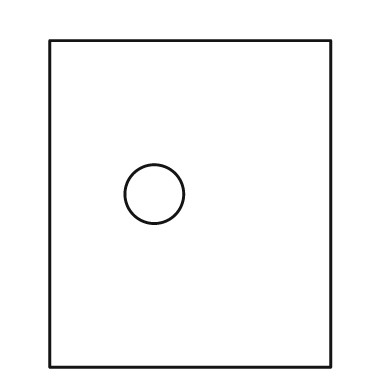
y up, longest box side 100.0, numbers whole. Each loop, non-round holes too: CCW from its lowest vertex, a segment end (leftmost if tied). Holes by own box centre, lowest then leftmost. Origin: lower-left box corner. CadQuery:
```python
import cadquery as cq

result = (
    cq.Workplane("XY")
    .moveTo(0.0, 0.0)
    .lineTo(86.0, 0.0)
    .lineTo(86.0, 100.0)
    .lineTo(0.0, 100.0)
    .close()
    .moveTo(32.0, 53.0)
    .circle(9.0)
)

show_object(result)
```